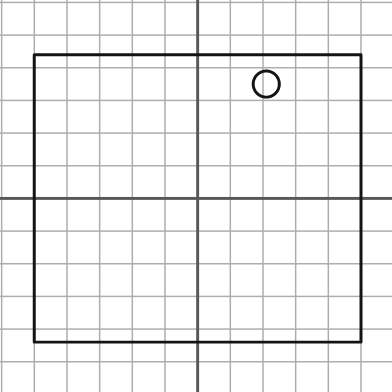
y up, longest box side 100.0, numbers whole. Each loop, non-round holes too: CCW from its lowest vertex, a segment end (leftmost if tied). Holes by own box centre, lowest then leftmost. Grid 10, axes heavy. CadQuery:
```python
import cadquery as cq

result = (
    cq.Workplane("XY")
    .moveTo(-50.0, -44.0)
    .lineTo(50.0, -44.0)
    .lineTo(50.0, 44.0)
    .lineTo(-50.0, 44.0)
    .close()
    .moveTo(21.0, 35.0)
    .circle(4.0)
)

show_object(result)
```